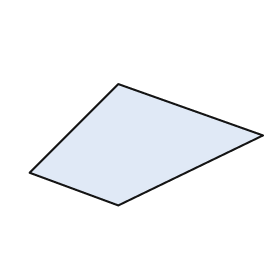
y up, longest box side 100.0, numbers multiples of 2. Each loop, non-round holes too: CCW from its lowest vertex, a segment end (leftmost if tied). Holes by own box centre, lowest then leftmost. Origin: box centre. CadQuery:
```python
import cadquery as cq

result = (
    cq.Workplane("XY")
    .moveTo(-12.0, -26.0)
    .lineTo(50.0, 4.0)
    .lineTo(-12.0, 26.0)
    .lineTo(-50.0, -12.0)
    .close()
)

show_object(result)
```